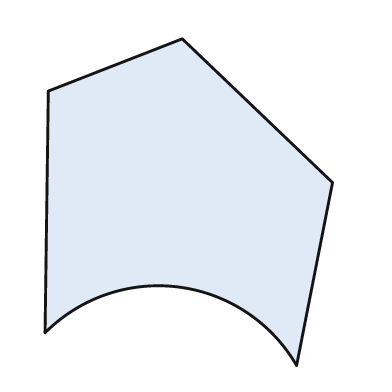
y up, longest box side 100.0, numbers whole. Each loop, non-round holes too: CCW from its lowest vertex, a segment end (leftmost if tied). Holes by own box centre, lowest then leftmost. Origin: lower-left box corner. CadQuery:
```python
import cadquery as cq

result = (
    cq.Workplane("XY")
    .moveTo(77.0, 0.0)
    .lineTo(88.0, 56.0)
    .lineTo(42.0, 100.0)
    .lineTo(1.0, 84.0)
    .lineTo(0.0, 10.0)
    .threePointArc((41.0, 24.0), (77.0, 0.0))
    .close()
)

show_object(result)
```